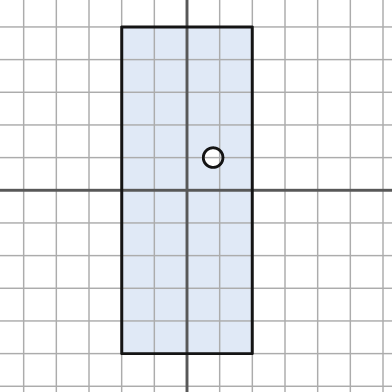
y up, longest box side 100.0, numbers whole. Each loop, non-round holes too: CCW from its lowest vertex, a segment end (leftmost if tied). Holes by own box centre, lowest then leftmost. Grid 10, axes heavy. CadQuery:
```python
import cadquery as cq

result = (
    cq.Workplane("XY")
    .moveTo(-20.0, -50.0)
    .lineTo(20.0, -50.0)
    .lineTo(20.0, 50.0)
    .lineTo(-20.0, 50.0)
    .close()
    .moveTo(8.0, 10.0)
    .circle(3.0)
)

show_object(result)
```